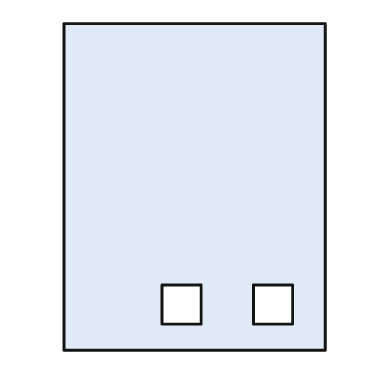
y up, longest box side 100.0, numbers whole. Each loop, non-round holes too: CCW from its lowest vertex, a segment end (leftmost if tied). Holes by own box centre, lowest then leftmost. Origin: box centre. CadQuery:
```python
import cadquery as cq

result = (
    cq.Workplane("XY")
    .moveTo(-40.0, -50.0)
    .lineTo(40.0, -50.0)
    .lineTo(40.0, 50.0)
    .lineTo(-40.0, 50.0)
    .close()
    .moveTo(-10.0, -42.0)
    .lineTo(2.0, -42.0)
    .lineTo(2.0, -30.0)
    .lineTo(-10.0, -30.0)
    .close()
    .moveTo(18.0, -42.0)
    .lineTo(30.0, -42.0)
    .lineTo(30.0, -30.0)
    .lineTo(18.0, -30.0)
    .close()
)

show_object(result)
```